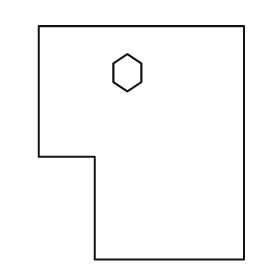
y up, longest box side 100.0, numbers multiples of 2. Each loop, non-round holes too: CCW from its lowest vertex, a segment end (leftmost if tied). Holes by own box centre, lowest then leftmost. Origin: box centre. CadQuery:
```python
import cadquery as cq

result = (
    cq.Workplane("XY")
    .moveTo(-20.0, -50.0)
    .lineTo(44.0, -50.0)
    .lineTo(44.0, 50.0)
    .lineTo(-44.0, 50.0)
    .lineTo(-44.0, -6.0)
    .lineTo(-20.0, -6.0)
    .close()
    .moveTo(-6.0, 22.0)
    .lineTo(0.0, 26.0)
    .lineTo(0.0, 34.0)
    .lineTo(-6.0, 38.0)
    .lineTo(-12.0, 34.0)
    .lineTo(-12.0, 26.0)
    .close()
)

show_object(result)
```